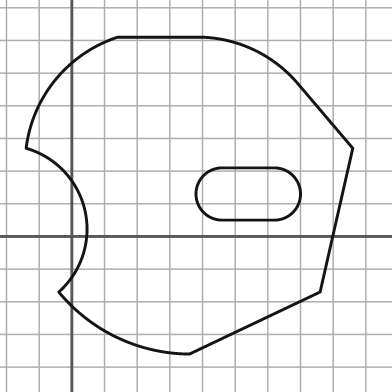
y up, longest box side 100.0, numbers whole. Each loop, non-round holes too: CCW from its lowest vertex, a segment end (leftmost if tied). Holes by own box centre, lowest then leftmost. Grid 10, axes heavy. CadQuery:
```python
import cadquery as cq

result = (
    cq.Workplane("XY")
    .moveTo(36.0, -36.0)
    .lineTo(76.0, -17.0)
    .lineTo(86.0, 27.0)
    .lineTo(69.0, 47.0)
    .threePointArc((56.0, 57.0), (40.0, 61.0))
    .lineTo(14.0, 61.0)
    .threePointArc((-5.0, 48.0), (-14.0, 27.0))
    .threePointArc((4.0, 8.0), (-4.0, -17.0))
    .threePointArc((14.0, -31.0), (36.0, -36.0))
    .close()
    .moveTo(46.0, 5.0)
    .lineTo(62.0, 5.0)
    .threePointArc((70.0, 13.0), (62.0, 21.0))
    .lineTo(46.0, 21.0)
    .threePointArc((38.0, 13.0), (46.0, 5.0))
    .close()
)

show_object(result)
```